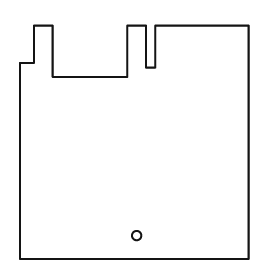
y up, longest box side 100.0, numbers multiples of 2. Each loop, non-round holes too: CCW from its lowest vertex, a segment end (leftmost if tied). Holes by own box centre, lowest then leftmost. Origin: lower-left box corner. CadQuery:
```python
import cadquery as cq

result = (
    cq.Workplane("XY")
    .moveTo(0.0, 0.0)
    .lineTo(98.0, 0.0)
    .lineTo(98.0, 100.0)
    .lineTo(58.0, 100.0)
    .lineTo(58.0, 82.0)
    .lineTo(54.0, 82.0)
    .lineTo(54.0, 100.0)
    .lineTo(46.0, 100.0)
    .lineTo(46.0, 78.0)
    .lineTo(14.0, 78.0)
    .lineTo(14.0, 100.0)
    .lineTo(6.0, 100.0)
    .lineTo(6.0, 84.0)
    .lineTo(0.0, 84.0)
    .close()
    .moveTo(50.0, 10.0)
    .circle(2.0)
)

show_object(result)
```